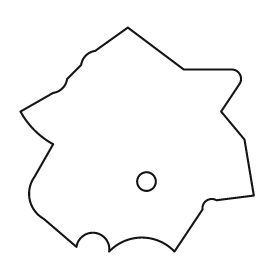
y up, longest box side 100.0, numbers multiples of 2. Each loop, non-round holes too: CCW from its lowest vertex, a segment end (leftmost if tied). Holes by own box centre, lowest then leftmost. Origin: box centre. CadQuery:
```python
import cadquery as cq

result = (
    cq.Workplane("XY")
    .moveTo(-12.0, -48.0)
    .threePointArc((2.0, -42.0), (16.0, -48.0))
    .lineTo(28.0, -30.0)
    .threePointArc((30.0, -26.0), (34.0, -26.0))
    .lineTo(50.0, -24.0)
    .lineTo(46.0, 0.0)
    .lineTo(36.0, 12.0)
    .lineTo(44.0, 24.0)
    .threePointArc((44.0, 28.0), (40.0, 30.0))
    .lineTo(20.0, 30.0)
    .lineTo(-4.0, 48.0)
    .lineTo(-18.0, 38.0)
    .threePointArc((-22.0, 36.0), (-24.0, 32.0))
    .lineTo(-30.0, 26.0)
    .threePointArc((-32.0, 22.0), (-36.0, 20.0))
    .lineTo(-50.0, 12.0)
    .threePointArc((-44.0, 4.0), (-36.0, -2.0))
    .lineTo(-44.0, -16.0)
    .threePointArc((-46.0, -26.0), (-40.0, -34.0))
    .lineTo(-26.0, -46.0)
    .threePointArc((-18.0, -40.0), (-12.0, -48.0))
    .close()
    .moveTo(4.0, -18.0)
    .circle(4.0)
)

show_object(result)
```